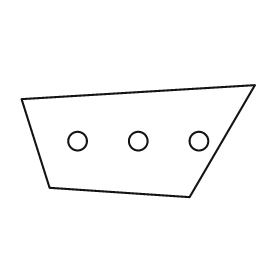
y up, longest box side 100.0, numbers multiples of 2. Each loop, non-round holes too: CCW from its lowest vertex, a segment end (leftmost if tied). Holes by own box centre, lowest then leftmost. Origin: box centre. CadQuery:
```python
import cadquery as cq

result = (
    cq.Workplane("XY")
    .moveTo(22.0, -24.0)
    .lineTo(50.0, 24.0)
    .lineTo(-50.0, 18.0)
    .lineTo(-38.0, -20.0)
    .close()
    .moveTo(-26.0, 0.0)
    .circle(4.0)
    .moveTo(0.0, 0.0)
    .circle(4.0)
    .moveTo(26.0, 0.0)
    .circle(4.0)
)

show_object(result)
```